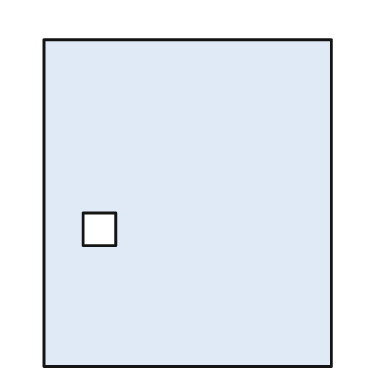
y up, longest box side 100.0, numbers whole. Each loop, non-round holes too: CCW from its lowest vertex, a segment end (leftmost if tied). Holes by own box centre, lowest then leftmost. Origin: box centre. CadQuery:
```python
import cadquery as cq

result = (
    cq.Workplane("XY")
    .moveTo(-44.0, -50.0)
    .lineTo(44.0, -50.0)
    .lineTo(44.0, 50.0)
    .lineTo(-44.0, 50.0)
    .close()
    .moveTo(-32.0, -13.0)
    .lineTo(-22.0, -13.0)
    .lineTo(-22.0, -3.0)
    .lineTo(-32.0, -3.0)
    .close()
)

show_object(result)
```